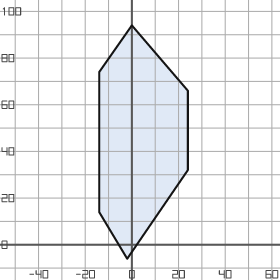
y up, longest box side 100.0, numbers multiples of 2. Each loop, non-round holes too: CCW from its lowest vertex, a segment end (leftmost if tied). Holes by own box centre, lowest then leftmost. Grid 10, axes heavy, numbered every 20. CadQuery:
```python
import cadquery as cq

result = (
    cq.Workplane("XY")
    .moveTo(-2.0, -6.0)
    .lineTo(24.0, 32.0)
    .lineTo(24.0, 66.0)
    .lineTo(0.0, 94.0)
    .lineTo(-14.0, 74.0)
    .lineTo(-14.0, 14.0)
    .close()
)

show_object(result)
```